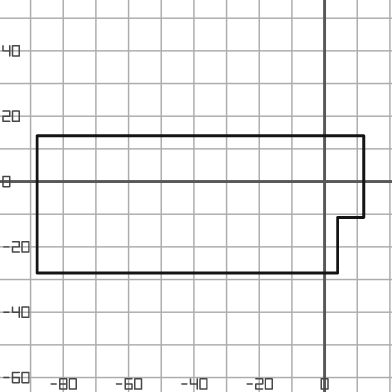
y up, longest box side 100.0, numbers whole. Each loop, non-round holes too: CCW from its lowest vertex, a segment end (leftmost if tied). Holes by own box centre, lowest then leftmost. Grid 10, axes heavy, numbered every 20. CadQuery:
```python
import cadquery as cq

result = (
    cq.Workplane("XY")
    .moveTo(-88.0, -28.0)
    .lineTo(4.0, -28.0)
    .lineTo(4.0, -11.0)
    .lineTo(12.0, -11.0)
    .lineTo(12.0, 14.0)
    .lineTo(-88.0, 14.0)
    .close()
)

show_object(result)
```